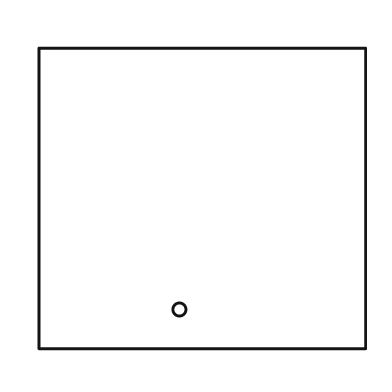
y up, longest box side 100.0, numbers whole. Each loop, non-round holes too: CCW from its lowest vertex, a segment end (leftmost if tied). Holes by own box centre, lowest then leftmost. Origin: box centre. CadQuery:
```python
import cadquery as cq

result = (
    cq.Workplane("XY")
    .moveTo(-50.0, -46.0)
    .lineTo(50.0, -46.0)
    .lineTo(50.0, 46.0)
    .lineTo(-50.0, 46.0)
    .close()
    .moveTo(-7.0, -34.0)
    .circle(2.0)
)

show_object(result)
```